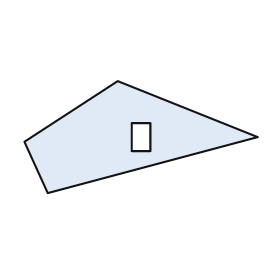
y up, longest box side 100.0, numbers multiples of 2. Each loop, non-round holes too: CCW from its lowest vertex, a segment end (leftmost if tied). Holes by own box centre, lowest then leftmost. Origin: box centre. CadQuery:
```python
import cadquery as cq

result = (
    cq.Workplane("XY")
    .moveTo(-40.0, -24.0)
    .lineTo(50.0, 0.0)
    .lineTo(-10.0, 24.0)
    .lineTo(-50.0, -2.0)
    .close()
    .moveTo(-4.0, -6.0)
    .lineTo(4.0, -6.0)
    .lineTo(4.0, 6.0)
    .lineTo(-4.0, 6.0)
    .close()
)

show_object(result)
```